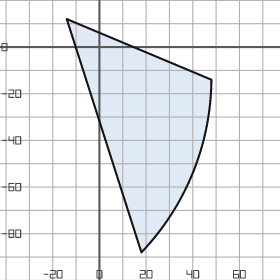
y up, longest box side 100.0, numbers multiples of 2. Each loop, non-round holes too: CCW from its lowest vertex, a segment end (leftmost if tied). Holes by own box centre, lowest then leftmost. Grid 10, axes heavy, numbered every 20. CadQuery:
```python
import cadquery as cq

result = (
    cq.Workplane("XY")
    .moveTo(18.0, -88.0)
    .threePointArc((40.0, -54.0), (48.0, -14.0))
    .lineTo(-14.0, 12.0)
    .close()
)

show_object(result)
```